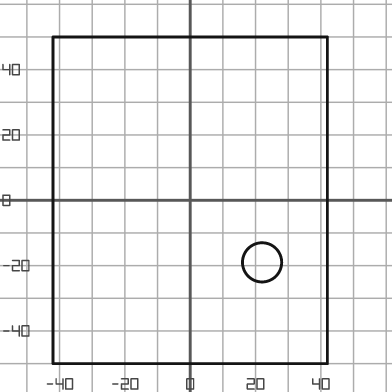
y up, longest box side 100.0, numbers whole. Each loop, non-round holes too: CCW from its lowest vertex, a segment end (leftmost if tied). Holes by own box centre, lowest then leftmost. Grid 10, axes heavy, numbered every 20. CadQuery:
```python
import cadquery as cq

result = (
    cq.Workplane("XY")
    .moveTo(-42.0, -50.0)
    .lineTo(42.0, -50.0)
    .lineTo(42.0, 50.0)
    .lineTo(-42.0, 50.0)
    .close()
    .moveTo(22.0, -19.0)
    .circle(6.0)
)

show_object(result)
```